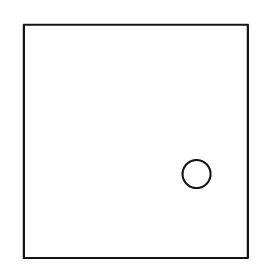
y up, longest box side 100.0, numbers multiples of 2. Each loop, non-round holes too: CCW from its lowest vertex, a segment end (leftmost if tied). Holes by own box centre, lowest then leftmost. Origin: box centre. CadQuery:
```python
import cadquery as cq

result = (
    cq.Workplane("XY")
    .moveTo(-48.0, -50.0)
    .lineTo(48.0, -50.0)
    .lineTo(48.0, 50.0)
    .lineTo(-48.0, 50.0)
    .close()
    .moveTo(26.0, -14.0)
    .circle(6.0)
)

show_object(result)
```